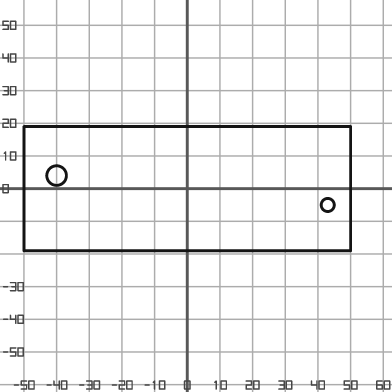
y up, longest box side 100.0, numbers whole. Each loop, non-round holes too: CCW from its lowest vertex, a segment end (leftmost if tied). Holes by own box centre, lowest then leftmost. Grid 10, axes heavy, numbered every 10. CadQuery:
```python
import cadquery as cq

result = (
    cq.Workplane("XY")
    .moveTo(-50.0, -19.0)
    .lineTo(50.0, -19.0)
    .lineTo(50.0, 19.0)
    .lineTo(-50.0, 19.0)
    .close()
    .moveTo(43.0, -5.0)
    .circle(2.0)
    .moveTo(-40.0, 4.0)
    .circle(3.0)
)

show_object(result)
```